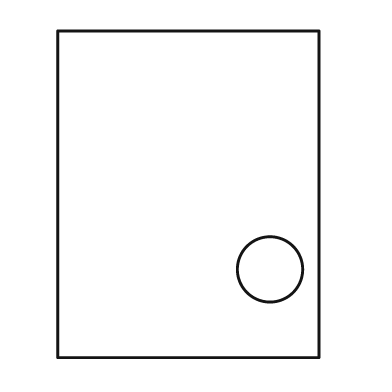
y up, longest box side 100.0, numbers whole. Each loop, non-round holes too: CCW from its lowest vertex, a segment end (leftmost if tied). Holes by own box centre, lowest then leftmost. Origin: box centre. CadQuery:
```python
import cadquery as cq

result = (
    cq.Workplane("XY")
    .moveTo(-40.0, -50.0)
    .lineTo(40.0, -50.0)
    .lineTo(40.0, 50.0)
    .lineTo(-40.0, 50.0)
    .close()
    .moveTo(25.0, -23.0)
    .circle(10.0)
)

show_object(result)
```